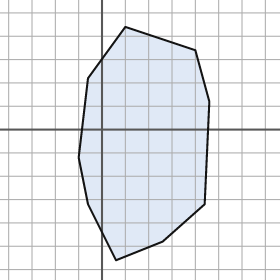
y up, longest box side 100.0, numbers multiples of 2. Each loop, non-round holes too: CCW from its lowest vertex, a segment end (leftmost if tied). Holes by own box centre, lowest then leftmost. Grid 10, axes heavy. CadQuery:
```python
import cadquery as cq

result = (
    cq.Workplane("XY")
    .moveTo(6.0, -56.0)
    .lineTo(26.0, -48.0)
    .lineTo(44.0, -32.0)
    .lineTo(46.0, 12.0)
    .lineTo(40.0, 34.0)
    .lineTo(10.0, 44.0)
    .lineTo(-6.0, 22.0)
    .lineTo(-10.0, -12.0)
    .lineTo(-6.0, -32.0)
    .close()
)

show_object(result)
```